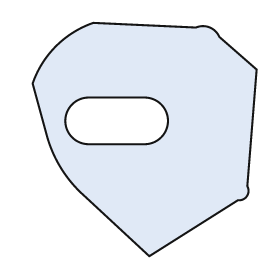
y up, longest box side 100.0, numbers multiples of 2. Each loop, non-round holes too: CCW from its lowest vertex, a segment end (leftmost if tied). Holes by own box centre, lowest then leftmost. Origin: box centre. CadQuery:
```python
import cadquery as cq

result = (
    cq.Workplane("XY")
    .moveTo(2.0, -50.0)
    .lineTo(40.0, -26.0)
    .threePointArc((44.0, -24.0), (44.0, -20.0))
    .lineTo(48.0, 30.0)
    .lineTo(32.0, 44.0)
    .threePointArc((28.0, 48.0), (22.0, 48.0))
    .lineTo(-22.0, 50.0)
    .threePointArc((-38.0, 40.0), (-48.0, 24.0))
    .lineTo(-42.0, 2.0)
    .threePointArc((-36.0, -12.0), (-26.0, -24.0))
    .close()
    .moveTo(-24.0, -2.0)
    .lineTo(0.0, -2.0)
    .threePointArc((10.0, 8.0), (0.0, 18.0))
    .lineTo(-24.0, 18.0)
    .threePointArc((-34.0, 8.0), (-24.0, -2.0))
    .close()
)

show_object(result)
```